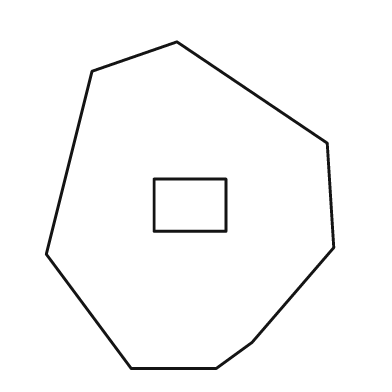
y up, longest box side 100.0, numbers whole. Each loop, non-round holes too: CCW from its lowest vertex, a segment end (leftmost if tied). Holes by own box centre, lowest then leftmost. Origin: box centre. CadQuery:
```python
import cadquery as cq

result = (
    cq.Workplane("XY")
    .moveTo(-18.0, -50.0)
    .lineTo(8.0, -50.0)
    .lineTo(19.0, -42.0)
    .lineTo(44.0, -13.0)
    .lineTo(42.0, 19.0)
    .lineTo(-4.0, 50.0)
    .lineTo(-30.0, 41.0)
    .lineTo(-44.0, -15.0)
    .close()
    .moveTo(-11.0, -8.0)
    .lineTo(11.0, -8.0)
    .lineTo(11.0, 8.0)
    .lineTo(-11.0, 8.0)
    .close()
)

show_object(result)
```